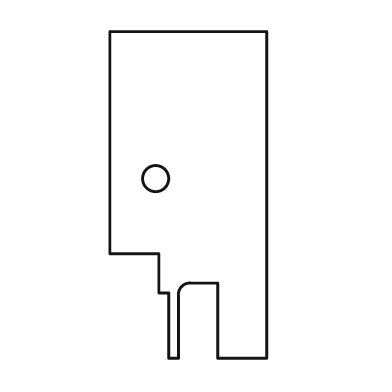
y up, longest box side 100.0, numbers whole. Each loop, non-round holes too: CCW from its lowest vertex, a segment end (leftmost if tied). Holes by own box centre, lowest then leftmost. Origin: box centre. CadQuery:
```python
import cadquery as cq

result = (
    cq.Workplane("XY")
    .moveTo(-6.0, -50.0)
    .lineTo(-3.0, -50.0)
    .lineTo(-3.0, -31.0)
    .threePointArc((-2.0, -28.0), (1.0, -27.0))
    .lineTo(9.0, -27.0)
    .lineTo(9.0, -50.0)
    .lineTo(24.0, -50.0)
    .lineTo(24.0, 50.0)
    .lineTo(-24.0, 50.0)
    .lineTo(-24.0, -18.0)
    .lineTo(-9.0, -18.0)
    .lineTo(-9.0, -30.0)
    .lineTo(-6.0, -30.0)
    .close()
    .moveTo(-10.0, 5.0)
    .circle(4.0)
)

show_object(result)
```